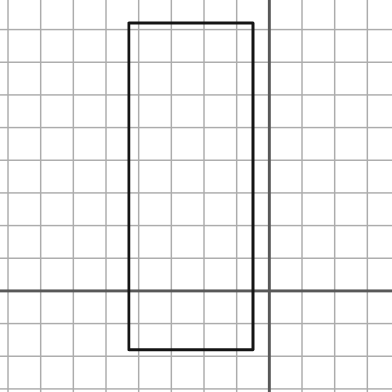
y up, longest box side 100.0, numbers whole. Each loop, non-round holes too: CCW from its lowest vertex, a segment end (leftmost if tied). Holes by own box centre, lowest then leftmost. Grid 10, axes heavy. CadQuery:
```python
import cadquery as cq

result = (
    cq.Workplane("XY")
    .moveTo(-43.0, -18.0)
    .lineTo(-5.0, -18.0)
    .lineTo(-5.0, 82.0)
    .lineTo(-43.0, 82.0)
    .close()
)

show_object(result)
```